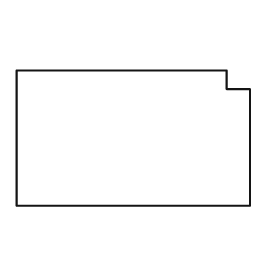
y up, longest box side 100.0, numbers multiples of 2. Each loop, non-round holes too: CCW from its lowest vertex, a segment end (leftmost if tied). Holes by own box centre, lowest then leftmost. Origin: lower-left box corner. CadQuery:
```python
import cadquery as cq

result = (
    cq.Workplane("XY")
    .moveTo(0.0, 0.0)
    .lineTo(100.0, 0.0)
    .lineTo(100.0, 50.0)
    .lineTo(90.0, 50.0)
    .lineTo(90.0, 58.0)
    .lineTo(0.0, 58.0)
    .close()
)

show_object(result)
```